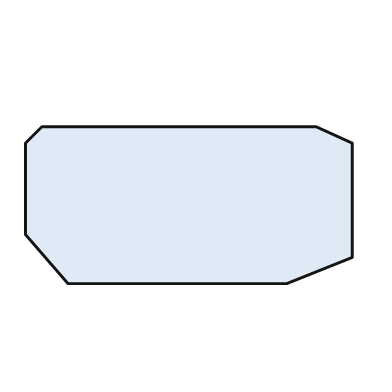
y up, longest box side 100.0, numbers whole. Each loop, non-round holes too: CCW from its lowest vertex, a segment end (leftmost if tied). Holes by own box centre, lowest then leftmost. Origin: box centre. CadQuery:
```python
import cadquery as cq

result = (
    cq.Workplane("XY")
    .moveTo(-37.0, -24.0)
    .lineTo(30.0, -24.0)
    .lineTo(50.0, -16.0)
    .lineTo(50.0, 19.0)
    .lineTo(39.0, 24.0)
    .lineTo(-45.0, 24.0)
    .lineTo(-50.0, 19.0)
    .lineTo(-50.0, -9.0)
    .close()
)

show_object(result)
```